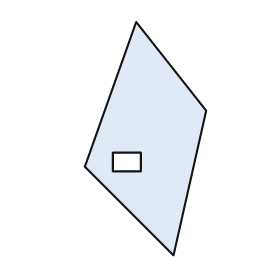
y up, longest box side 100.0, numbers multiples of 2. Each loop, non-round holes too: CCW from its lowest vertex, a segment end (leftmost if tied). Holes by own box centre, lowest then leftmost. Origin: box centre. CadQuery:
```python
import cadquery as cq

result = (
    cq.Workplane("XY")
    .moveTo(12.0, -50.0)
    .lineTo(26.0, 12.0)
    .lineTo(-4.0, 50.0)
    .lineTo(-26.0, -12.0)
    .close()
    .moveTo(-14.0, -14.0)
    .lineTo(-2.0, -14.0)
    .lineTo(-2.0, -6.0)
    .lineTo(-14.0, -6.0)
    .close()
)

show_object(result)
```